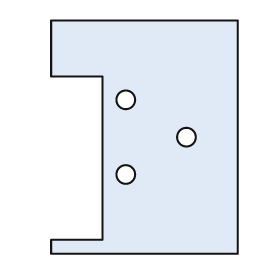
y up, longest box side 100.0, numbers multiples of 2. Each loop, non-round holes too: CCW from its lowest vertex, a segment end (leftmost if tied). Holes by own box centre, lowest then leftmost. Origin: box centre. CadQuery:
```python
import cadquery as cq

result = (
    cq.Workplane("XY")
    .moveTo(-40.0, -50.0)
    .lineTo(40.0, -50.0)
    .lineTo(40.0, 50.0)
    .lineTo(-40.0, 50.0)
    .lineTo(-40.0, 26.0)
    .lineTo(-18.0, 26.0)
    .lineTo(-18.0, -44.0)
    .lineTo(-40.0, -44.0)
    .close()
    .moveTo(-8.0, -16.0)
    .circle(4.0)
    .moveTo(18.0, 0.0)
    .circle(4.0)
    .moveTo(-8.0, 16.0)
    .circle(4.0)
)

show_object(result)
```